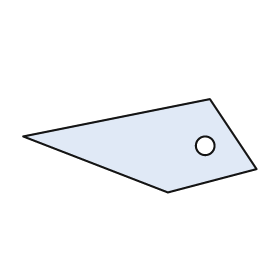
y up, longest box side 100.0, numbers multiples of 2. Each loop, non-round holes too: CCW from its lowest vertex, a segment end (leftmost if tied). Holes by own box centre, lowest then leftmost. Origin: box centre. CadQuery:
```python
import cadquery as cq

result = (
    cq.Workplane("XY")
    .moveTo(12.0, -20.0)
    .lineTo(50.0, -10.0)
    .lineTo(30.0, 20.0)
    .lineTo(-50.0, 4.0)
    .close()
    .moveTo(28.0, 0.0)
    .circle(4.0)
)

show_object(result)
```